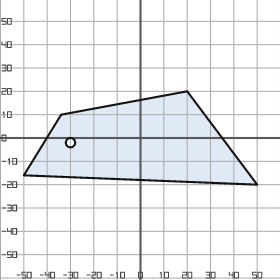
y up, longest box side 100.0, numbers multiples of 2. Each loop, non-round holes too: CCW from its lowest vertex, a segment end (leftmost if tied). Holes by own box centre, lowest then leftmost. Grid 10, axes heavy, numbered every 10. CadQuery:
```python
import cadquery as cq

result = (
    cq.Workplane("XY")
    .moveTo(50.0, -20.0)
    .lineTo(20.0, 20.0)
    .lineTo(-34.0, 10.0)
    .lineTo(-50.0, -16.0)
    .close()
    .moveTo(-30.0, -2.0)
    .circle(2.0)
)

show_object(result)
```